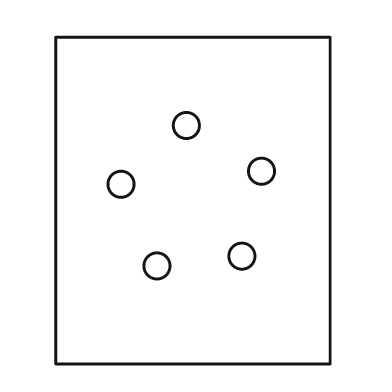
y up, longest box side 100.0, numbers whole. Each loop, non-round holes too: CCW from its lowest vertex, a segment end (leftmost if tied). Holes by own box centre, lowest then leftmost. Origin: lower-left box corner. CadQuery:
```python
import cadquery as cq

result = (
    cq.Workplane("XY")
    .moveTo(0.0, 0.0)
    .lineTo(84.0, 0.0)
    .lineTo(84.0, 100.0)
    .lineTo(0.0, 100.0)
    .close()
    .moveTo(31.0, 30.0)
    .circle(4.0)
    .moveTo(57.0, 33.0)
    .circle(4.0)
    .moveTo(20.0, 55.0)
    .circle(4.0)
    .moveTo(63.0, 59.0)
    .circle(4.0)
    .moveTo(40.0, 73.0)
    .circle(4.0)
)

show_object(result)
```